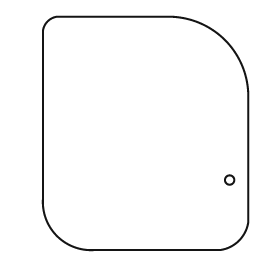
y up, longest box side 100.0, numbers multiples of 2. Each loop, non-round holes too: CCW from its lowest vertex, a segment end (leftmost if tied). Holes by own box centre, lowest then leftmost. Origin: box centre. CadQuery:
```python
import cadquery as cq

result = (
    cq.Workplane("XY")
    .moveTo(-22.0, -50.0)
    .lineTo(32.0, -50.0)
    .threePointArc((40.0, -46.0), (44.0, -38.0))
    .lineTo(44.0, 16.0)
    .threePointArc((34.0, 40.0), (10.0, 50.0))
    .lineTo(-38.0, 50.0)
    .threePointArc((-42.0, 48.0), (-44.0, 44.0))
    .lineTo(-44.0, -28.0)
    .threePointArc((-38.0, -44.0), (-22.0, -50.0))
    .close()
    .moveTo(36.0, -20.0)
    .circle(2.0)
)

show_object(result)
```